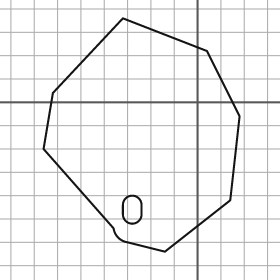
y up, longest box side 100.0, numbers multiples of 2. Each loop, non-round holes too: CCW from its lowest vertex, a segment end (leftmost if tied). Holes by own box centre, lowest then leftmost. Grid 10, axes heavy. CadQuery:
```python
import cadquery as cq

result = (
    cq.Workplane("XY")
    .moveTo(-14.0, -64.0)
    .lineTo(14.0, -42.0)
    .lineTo(18.0, -6.0)
    .lineTo(4.0, 22.0)
    .lineTo(-32.0, 36.0)
    .lineTo(-62.0, 4.0)
    .lineTo(-66.0, -20.0)
    .lineTo(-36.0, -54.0)
    .threePointArc((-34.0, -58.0), (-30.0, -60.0))
    .close()
    .moveTo(-32.0, -48.0)
    .threePointArc((-28.0, -52.0), (-24.0, -48.0))
    .lineTo(-24.0, -44.0)
    .threePointArc((-28.0, -40.0), (-32.0, -44.0))
    .close()
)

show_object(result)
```